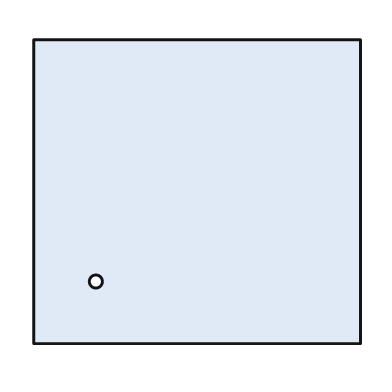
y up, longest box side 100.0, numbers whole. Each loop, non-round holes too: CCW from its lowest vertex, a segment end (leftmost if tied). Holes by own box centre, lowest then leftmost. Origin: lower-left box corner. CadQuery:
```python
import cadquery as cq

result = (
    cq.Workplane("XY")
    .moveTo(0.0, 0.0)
    .lineTo(100.0, 0.0)
    .lineTo(100.0, 93.0)
    .lineTo(0.0, 93.0)
    .close()
    .moveTo(19.0, 19.0)
    .circle(2.0)
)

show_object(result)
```